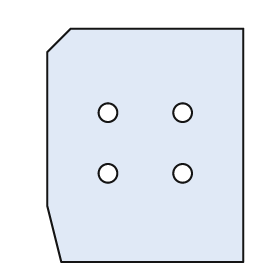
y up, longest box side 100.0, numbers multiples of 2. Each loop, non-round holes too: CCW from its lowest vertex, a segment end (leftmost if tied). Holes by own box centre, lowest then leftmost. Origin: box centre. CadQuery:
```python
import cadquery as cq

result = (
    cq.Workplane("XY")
    .moveTo(-36.0, -50.0)
    .lineTo(42.0, -50.0)
    .lineTo(42.0, 50.0)
    .lineTo(-32.0, 50.0)
    .lineTo(-42.0, 40.0)
    .lineTo(-42.0, -26.0)
    .close()
    .moveTo(-16.0, -12.0)
    .circle(4.0)
    .moveTo(16.0, -12.0)
    .circle(4.0)
    .moveTo(-16.0, 14.0)
    .circle(4.0)
    .moveTo(16.0, 14.0)
    .circle(4.0)
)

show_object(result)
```